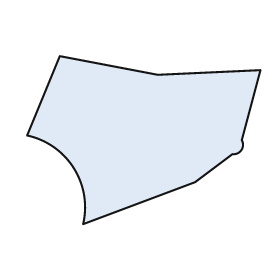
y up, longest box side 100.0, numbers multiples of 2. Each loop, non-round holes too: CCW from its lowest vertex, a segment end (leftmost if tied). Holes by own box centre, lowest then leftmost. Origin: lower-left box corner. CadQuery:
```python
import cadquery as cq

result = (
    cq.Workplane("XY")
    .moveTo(24.0, 0.0)
    .lineTo(72.0, 18.0)
    .lineTo(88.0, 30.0)
    .threePointArc((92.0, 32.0), (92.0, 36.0))
    .lineTo(100.0, 66.0)
    .lineTo(56.0, 64.0)
    .lineTo(14.0, 72.0)
    .lineTo(0.0, 38.0)
    .threePointArc((20.0, 24.0), (24.0, 0.0))
    .close()
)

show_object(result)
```